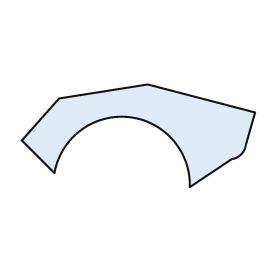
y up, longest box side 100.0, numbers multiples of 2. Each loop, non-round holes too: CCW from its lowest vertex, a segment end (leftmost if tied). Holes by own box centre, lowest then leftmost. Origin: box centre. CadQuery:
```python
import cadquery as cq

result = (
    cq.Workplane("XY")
    .moveTo(22.0, -22.0)
    .lineTo(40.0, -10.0)
    .threePointArc((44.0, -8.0), (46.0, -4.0))
    .lineTo(50.0, 10.0)
    .lineTo(4.0, 22.0)
    .lineTo(-34.0, 16.0)
    .lineTo(-50.0, -2.0)
    .lineTo(-36.0, -16.0)
    .threePointArc((-4.0, 8.0), (22.0, -22.0))
    .close()
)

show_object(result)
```